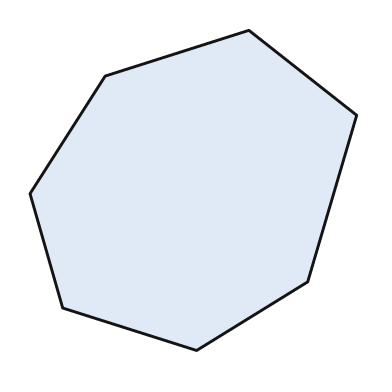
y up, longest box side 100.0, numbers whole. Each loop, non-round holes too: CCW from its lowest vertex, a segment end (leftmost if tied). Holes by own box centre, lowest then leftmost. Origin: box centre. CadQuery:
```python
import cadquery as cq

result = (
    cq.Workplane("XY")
    .moveTo(1.0, -49.0)
    .lineTo(35.0, -28.0)
    .lineTo(50.0, 23.0)
    .lineTo(17.0, 49.0)
    .lineTo(-27.0, 35.0)
    .lineTo(-50.0, -1.0)
    .lineTo(-40.0, -36.0)
    .close()
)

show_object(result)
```